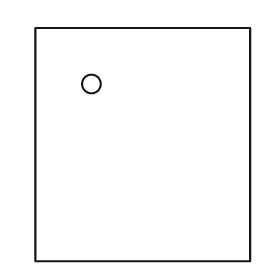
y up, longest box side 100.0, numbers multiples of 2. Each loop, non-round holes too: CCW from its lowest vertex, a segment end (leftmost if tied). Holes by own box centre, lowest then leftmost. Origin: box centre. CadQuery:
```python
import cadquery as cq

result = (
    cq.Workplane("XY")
    .moveTo(-46.0, -50.0)
    .lineTo(46.0, -50.0)
    .lineTo(46.0, 50.0)
    .lineTo(-46.0, 50.0)
    .close()
    .moveTo(-22.0, 26.0)
    .circle(4.0)
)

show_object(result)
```